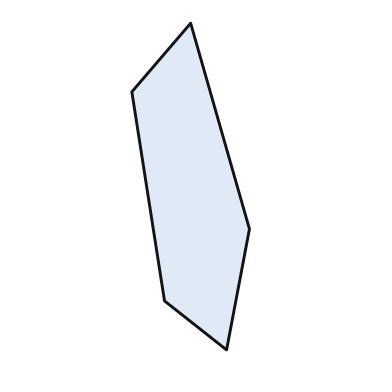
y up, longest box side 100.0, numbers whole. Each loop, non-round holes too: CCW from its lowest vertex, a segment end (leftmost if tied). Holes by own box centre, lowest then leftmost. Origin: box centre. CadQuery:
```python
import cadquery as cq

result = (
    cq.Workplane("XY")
    .moveTo(11.0, -50.0)
    .lineTo(18.0, -13.0)
    .lineTo(0.0, 50.0)
    .lineTo(-18.0, 29.0)
    .lineTo(-8.0, -35.0)
    .close()
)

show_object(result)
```